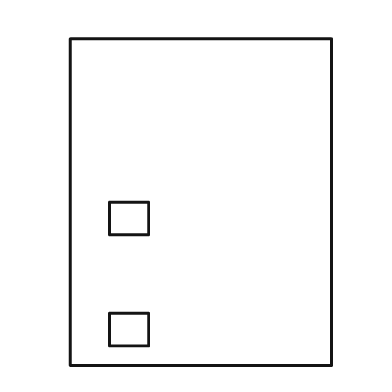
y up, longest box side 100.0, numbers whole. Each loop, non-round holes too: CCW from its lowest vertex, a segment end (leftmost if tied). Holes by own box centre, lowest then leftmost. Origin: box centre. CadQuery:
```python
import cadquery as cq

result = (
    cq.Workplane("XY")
    .moveTo(-40.0, -50.0)
    .lineTo(40.0, -50.0)
    .lineTo(40.0, 50.0)
    .lineTo(-40.0, 50.0)
    .close()
    .moveTo(-28.0, -44.0)
    .lineTo(-16.0, -44.0)
    .lineTo(-16.0, -34.0)
    .lineTo(-28.0, -34.0)
    .close()
    .moveTo(-28.0, -10.0)
    .lineTo(-16.0, -10.0)
    .lineTo(-16.0, 0.0)
    .lineTo(-28.0, 0.0)
    .close()
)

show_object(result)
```